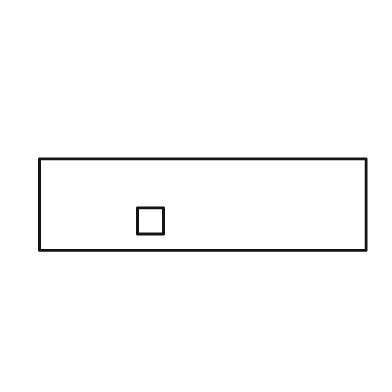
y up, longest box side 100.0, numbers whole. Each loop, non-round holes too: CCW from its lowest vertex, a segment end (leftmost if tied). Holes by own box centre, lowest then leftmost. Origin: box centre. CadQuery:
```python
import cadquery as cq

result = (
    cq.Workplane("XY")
    .moveTo(-50.0, -14.0)
    .lineTo(50.0, -14.0)
    .lineTo(50.0, 14.0)
    .lineTo(-50.0, 14.0)
    .close()
    .moveTo(-20.0, -9.0)
    .lineTo(-12.0, -9.0)
    .lineTo(-12.0, -1.0)
    .lineTo(-20.0, -1.0)
    .close()
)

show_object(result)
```